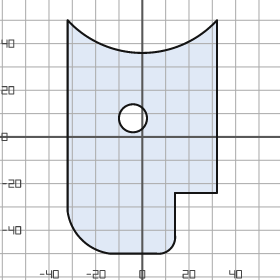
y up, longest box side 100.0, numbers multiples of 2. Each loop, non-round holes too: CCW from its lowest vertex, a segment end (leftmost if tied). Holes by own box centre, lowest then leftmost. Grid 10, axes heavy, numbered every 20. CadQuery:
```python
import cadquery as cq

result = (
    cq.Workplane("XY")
    .moveTo(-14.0, -50.0)
    .lineTo(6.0, -50.0)
    .threePointArc((12.0, -48.0), (14.0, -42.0))
    .lineTo(14.0, -24.0)
    .lineTo(32.0, -24.0)
    .lineTo(32.0, 50.0)
    .threePointArc((0.0, 36.0), (-32.0, 50.0))
    .lineTo(-32.0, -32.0)
    .threePointArc((-26.0, -44.0), (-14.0, -50.0))
    .close()
    .moveTo(-4.0, 8.0)
    .circle(6.0)
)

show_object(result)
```